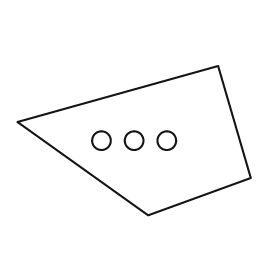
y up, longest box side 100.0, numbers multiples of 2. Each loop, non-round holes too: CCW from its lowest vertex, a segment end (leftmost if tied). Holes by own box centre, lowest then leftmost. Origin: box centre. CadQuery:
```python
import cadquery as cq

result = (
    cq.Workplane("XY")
    .moveTo(6.0, -32.0)
    .lineTo(50.0, -16.0)
    .lineTo(36.0, 32.0)
    .lineTo(-50.0, 8.0)
    .close()
    .moveTo(-14.0, 0.0)
    .circle(4.0)
    .moveTo(0.0, 0.0)
    .circle(4.0)
    .moveTo(14.0, 0.0)
    .circle(4.0)
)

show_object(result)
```